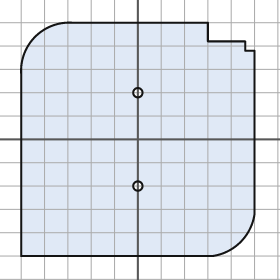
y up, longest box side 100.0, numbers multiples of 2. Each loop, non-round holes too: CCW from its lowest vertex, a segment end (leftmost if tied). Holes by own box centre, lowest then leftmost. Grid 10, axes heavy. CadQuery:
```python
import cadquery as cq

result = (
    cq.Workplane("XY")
    .moveTo(-50.0, -50.0)
    .lineTo(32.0, -50.0)
    .threePointArc((44.0, -44.0), (50.0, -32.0))
    .lineTo(50.0, 38.0)
    .lineTo(46.0, 38.0)
    .lineTo(46.0, 42.0)
    .lineTo(30.0, 42.0)
    .lineTo(30.0, 50.0)
    .lineTo(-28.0, 50.0)
    .threePointArc((-44.0, 44.0), (-50.0, 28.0))
    .close()
    .moveTo(0.0, -20.0)
    .circle(2.0)
    .moveTo(0.0, 20.0)
    .circle(2.0)
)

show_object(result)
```